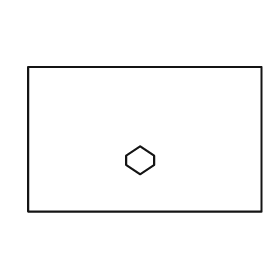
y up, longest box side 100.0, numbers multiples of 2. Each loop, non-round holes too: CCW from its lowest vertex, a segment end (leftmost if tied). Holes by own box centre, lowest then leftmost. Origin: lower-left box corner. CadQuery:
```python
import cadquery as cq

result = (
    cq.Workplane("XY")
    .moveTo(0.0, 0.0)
    .lineTo(100.0, 0.0)
    .lineTo(100.0, 62.0)
    .lineTo(0.0, 62.0)
    .close()
    .moveTo(48.0, 16.0)
    .lineTo(54.0, 20.0)
    .lineTo(54.0, 24.0)
    .lineTo(48.0, 28.0)
    .lineTo(42.0, 24.0)
    .lineTo(42.0, 20.0)
    .close()
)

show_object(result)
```